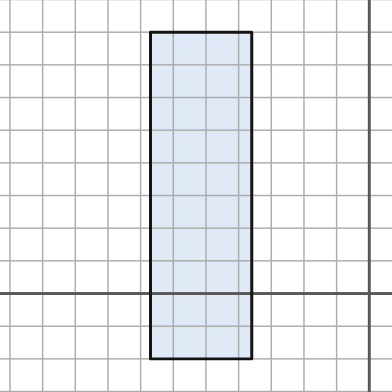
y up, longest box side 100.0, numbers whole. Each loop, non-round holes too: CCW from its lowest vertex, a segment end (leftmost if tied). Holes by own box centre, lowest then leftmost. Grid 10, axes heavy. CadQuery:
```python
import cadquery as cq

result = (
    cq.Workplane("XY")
    .moveTo(-67.0, -20.0)
    .lineTo(-36.0, -20.0)
    .lineTo(-36.0, 80.0)
    .lineTo(-67.0, 80.0)
    .close()
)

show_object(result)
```